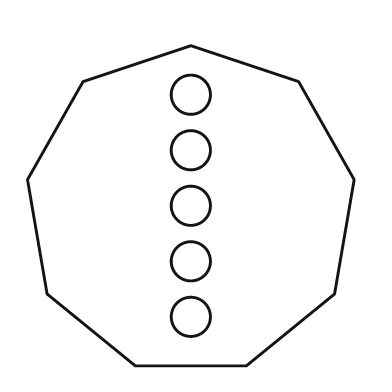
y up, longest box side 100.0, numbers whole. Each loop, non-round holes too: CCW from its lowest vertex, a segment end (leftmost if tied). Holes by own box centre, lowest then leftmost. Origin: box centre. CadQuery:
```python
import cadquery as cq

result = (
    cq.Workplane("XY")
    .moveTo(-17.0, -49.0)
    .lineTo(17.0, -49.0)
    .lineTo(44.0, -27.0)
    .lineTo(50.0, 8.0)
    .lineTo(33.0, 38.0)
    .lineTo(0.0, 49.0)
    .lineTo(-33.0, 38.0)
    .lineTo(-50.0, 8.0)
    .lineTo(-44.0, -27.0)
    .close()
    .moveTo(0.0, -34.0)
    .circle(6.0)
    .moveTo(0.0, -17.0)
    .circle(6.0)
    .moveTo(0.0, 0.0)
    .circle(6.0)
    .moveTo(0.0, 17.0)
    .circle(6.0)
    .moveTo(0.0, 34.0)
    .circle(6.0)
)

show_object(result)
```